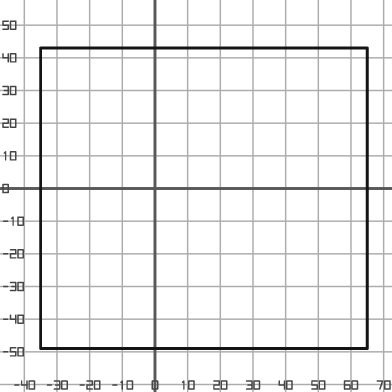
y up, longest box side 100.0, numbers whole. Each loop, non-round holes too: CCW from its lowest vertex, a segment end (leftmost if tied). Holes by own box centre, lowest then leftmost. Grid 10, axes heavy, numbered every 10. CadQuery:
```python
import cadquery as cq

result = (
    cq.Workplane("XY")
    .moveTo(-35.0, -49.0)
    .lineTo(65.0, -49.0)
    .lineTo(65.0, 43.0)
    .lineTo(-35.0, 43.0)
    .close()
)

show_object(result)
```